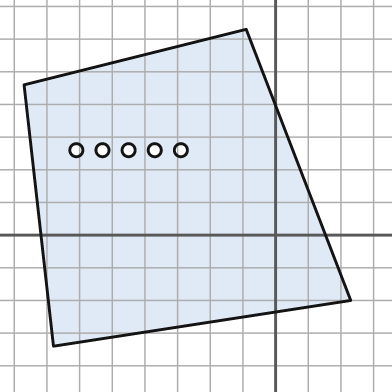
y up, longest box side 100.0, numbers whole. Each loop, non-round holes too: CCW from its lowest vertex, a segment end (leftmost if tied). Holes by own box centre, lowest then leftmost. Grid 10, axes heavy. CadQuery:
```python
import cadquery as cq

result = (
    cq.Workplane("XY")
    .moveTo(-68.0, -34.0)
    .lineTo(23.0, -20.0)
    .lineTo(-9.0, 63.0)
    .lineTo(-77.0, 46.0)
    .close()
    .moveTo(-61.0, 26.0)
    .circle(2.0)
    .moveTo(-53.0, 26.0)
    .circle(2.0)
    .moveTo(-45.0, 26.0)
    .circle(2.0)
    .moveTo(-37.0, 26.0)
    .circle(2.0)
    .moveTo(-29.0, 26.0)
    .circle(2.0)
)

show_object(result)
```